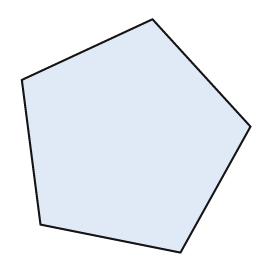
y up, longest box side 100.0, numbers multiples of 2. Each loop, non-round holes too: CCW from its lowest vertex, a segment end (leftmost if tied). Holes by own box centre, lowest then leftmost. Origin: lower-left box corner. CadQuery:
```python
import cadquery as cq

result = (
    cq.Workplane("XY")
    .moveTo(68.0, 0.0)
    .lineTo(98.0, 54.0)
    .lineTo(56.0, 100.0)
    .lineTo(0.0, 74.0)
    .lineTo(8.0, 12.0)
    .close()
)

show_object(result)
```